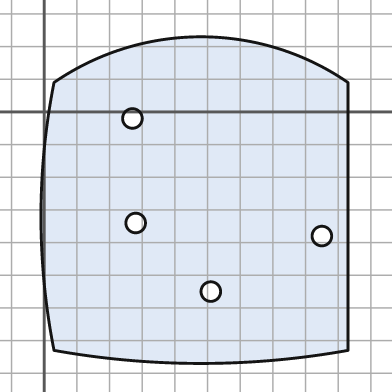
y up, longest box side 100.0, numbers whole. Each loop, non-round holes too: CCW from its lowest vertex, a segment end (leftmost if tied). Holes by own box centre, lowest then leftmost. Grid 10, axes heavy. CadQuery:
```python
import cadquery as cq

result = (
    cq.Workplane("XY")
    .moveTo(3.0, -73.0)
    .threePointArc((48.0, -77.0), (93.0, -73.0))
    .lineTo(93.0, 9.0)
    .threePointArc((48.0, 23.0), (3.0, 9.0))
    .threePointArc((-1.0, -32.0), (3.0, -73.0))
    .close()
    .moveTo(51.0, -55.0)
    .circle(3.0)
    .moveTo(85.0, -38.0)
    .circle(3.0)
    .moveTo(28.0, -34.0)
    .circle(3.0)
    .moveTo(27.0, -2.0)
    .circle(3.0)
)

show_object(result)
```